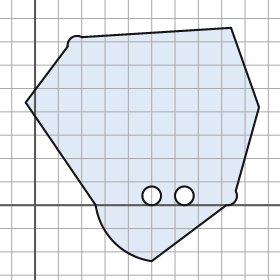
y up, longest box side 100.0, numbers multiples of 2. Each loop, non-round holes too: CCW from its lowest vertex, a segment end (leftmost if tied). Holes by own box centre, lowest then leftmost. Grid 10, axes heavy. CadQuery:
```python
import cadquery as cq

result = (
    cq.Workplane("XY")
    .moveTo(50.0, -24.0)
    .lineTo(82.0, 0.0)
    .threePointArc((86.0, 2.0), (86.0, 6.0))
    .lineTo(96.0, 42.0)
    .lineTo(84.0, 76.0)
    .lineTo(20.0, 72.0)
    .threePointArc((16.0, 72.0), (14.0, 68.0))
    .lineTo(-4.0, 44.0)
    .lineTo(26.0, 0.0)
    .threePointArc((34.0, -16.0), (50.0, -24.0))
    .close()
    .moveTo(50.0, 4.0)
    .circle(4.0)
    .moveTo(64.0, 4.0)
    .circle(4.0)
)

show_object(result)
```